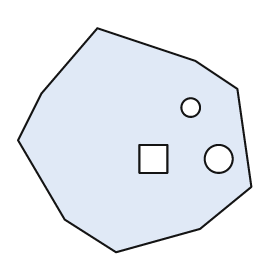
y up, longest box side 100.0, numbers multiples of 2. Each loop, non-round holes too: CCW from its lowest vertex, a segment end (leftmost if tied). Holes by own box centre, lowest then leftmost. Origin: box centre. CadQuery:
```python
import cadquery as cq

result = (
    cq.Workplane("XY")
    .moveTo(-8.0, -48.0)
    .lineTo(28.0, -38.0)
    .lineTo(50.0, -20.0)
    .lineTo(44.0, 22.0)
    .lineTo(26.0, 34.0)
    .lineTo(-16.0, 48.0)
    .lineTo(-40.0, 20.0)
    .lineTo(-50.0, 0.0)
    .lineTo(-30.0, -34.0)
    .close()
    .moveTo(2.0, -14.0)
    .lineTo(14.0, -14.0)
    .lineTo(14.0, -2.0)
    .lineTo(2.0, -2.0)
    .close()
    .moveTo(36.0, -8.0)
    .circle(6.0)
    .moveTo(24.0, 14.0)
    .circle(4.0)
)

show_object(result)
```